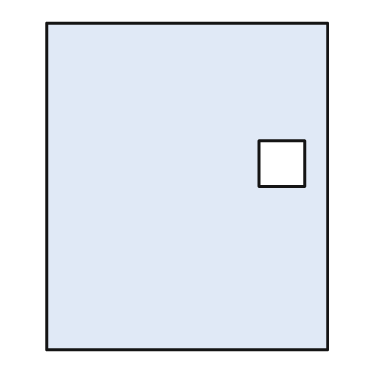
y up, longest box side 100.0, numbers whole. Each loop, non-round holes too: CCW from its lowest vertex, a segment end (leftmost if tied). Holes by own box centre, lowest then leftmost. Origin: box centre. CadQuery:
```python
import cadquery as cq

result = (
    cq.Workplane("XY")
    .moveTo(-43.0, -50.0)
    .lineTo(43.0, -50.0)
    .lineTo(43.0, 50.0)
    .lineTo(-43.0, 50.0)
    .close()
    .moveTo(22.0, 0.0)
    .lineTo(36.0, 0.0)
    .lineTo(36.0, 14.0)
    .lineTo(22.0, 14.0)
    .close()
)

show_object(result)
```